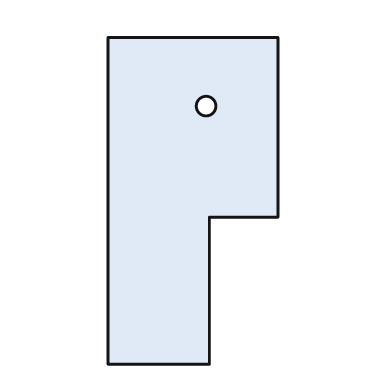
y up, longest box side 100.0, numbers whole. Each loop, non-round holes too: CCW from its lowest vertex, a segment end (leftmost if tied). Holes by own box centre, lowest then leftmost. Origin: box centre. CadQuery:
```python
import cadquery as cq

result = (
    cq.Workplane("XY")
    .moveTo(-26.0, -50.0)
    .lineTo(5.0, -50.0)
    .lineTo(5.0, -5.0)
    .lineTo(26.0, -5.0)
    .lineTo(26.0, 50.0)
    .lineTo(-26.0, 50.0)
    .close()
    .moveTo(4.0, 29.0)
    .circle(3.0)
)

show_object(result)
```